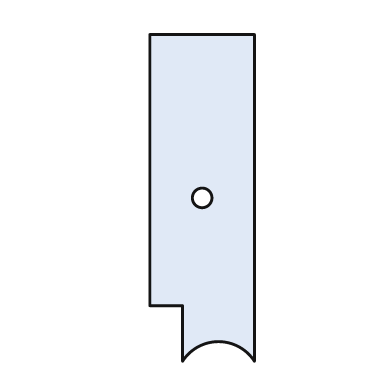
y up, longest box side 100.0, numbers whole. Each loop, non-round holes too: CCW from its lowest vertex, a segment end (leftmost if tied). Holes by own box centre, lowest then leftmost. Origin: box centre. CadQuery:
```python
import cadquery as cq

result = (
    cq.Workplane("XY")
    .moveTo(-6.0, -50.0)
    .threePointArc((5.0, -44.0), (16.0, -50.0))
    .lineTo(16.0, 50.0)
    .lineTo(-16.0, 50.0)
    .lineTo(-16.0, -33.0)
    .lineTo(-6.0, -33.0)
    .close()
    .moveTo(0.0, 0.0)
    .circle(3.0)
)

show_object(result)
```